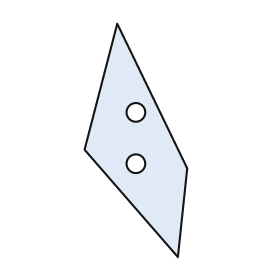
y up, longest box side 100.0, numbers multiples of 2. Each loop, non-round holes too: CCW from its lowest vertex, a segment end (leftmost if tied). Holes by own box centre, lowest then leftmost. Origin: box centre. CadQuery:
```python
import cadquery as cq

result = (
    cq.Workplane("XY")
    .moveTo(18.0, -50.0)
    .lineTo(22.0, -12.0)
    .lineTo(-8.0, 50.0)
    .lineTo(-22.0, -4.0)
    .close()
    .moveTo(0.0, -10.0)
    .circle(4.0)
    .moveTo(0.0, 12.0)
    .circle(4.0)
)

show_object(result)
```